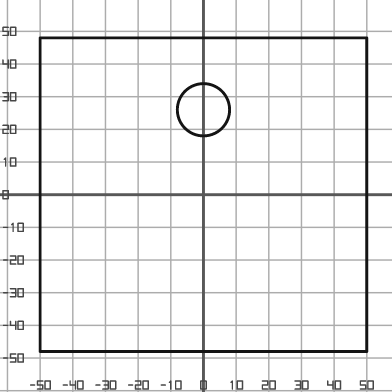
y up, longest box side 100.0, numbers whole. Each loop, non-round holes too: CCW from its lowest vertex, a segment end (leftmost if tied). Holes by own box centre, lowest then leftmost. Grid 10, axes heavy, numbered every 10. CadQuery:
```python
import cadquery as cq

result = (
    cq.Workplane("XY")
    .moveTo(-50.0, -48.0)
    .lineTo(50.0, -48.0)
    .lineTo(50.0, 48.0)
    .lineTo(-50.0, 48.0)
    .close()
    .moveTo(0.0, 26.0)
    .circle(8.0)
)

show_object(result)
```